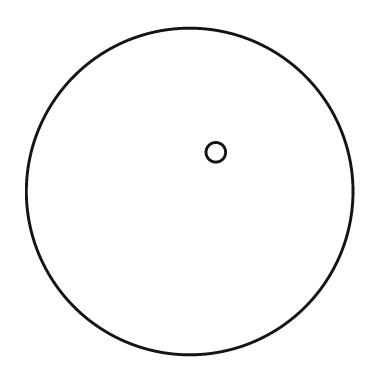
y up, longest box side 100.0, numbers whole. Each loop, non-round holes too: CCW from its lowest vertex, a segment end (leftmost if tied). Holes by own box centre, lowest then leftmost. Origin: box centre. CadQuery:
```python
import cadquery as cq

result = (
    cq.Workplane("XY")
    .moveTo(0.0, 0.0)
    .circle(50.0)
    .moveTo(8.0, 12.0)
    .circle(3.0)
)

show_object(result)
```